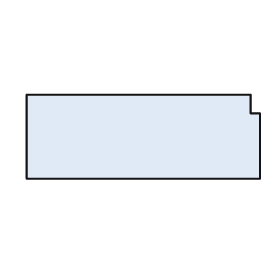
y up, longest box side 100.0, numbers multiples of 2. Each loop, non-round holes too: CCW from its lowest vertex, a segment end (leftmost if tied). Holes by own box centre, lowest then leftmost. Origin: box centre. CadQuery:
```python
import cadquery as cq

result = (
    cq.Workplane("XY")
    .moveTo(-50.0, -18.0)
    .lineTo(50.0, -18.0)
    .lineTo(50.0, 10.0)
    .lineTo(46.0, 10.0)
    .lineTo(46.0, 18.0)
    .lineTo(-50.0, 18.0)
    .close()
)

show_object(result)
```